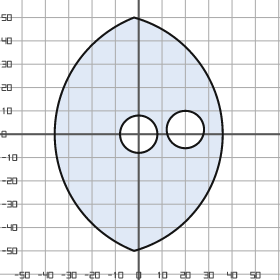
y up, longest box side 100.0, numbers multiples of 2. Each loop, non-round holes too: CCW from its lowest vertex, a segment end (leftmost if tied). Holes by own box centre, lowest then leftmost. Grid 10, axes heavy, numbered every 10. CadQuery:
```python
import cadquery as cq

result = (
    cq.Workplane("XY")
    .moveTo(-2.0, -50.0)
    .threePointArc((36.0, 0.0), (-2.0, 50.0))
    .threePointArc((-36.0, 0.0), (-2.0, -50.0))
    .close()
    .moveTo(0.0, 0.0)
    .circle(8.0)
    .moveTo(20.0, 2.0)
    .circle(8.0)
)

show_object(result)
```